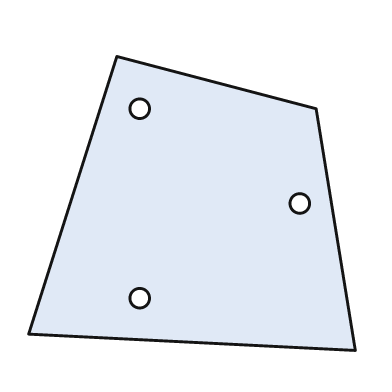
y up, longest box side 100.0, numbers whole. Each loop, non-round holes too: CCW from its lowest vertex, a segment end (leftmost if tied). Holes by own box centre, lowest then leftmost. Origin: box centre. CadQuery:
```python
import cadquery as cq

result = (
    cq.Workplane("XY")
    .moveTo(50.0, -45.0)
    .lineTo(38.0, 29.0)
    .lineTo(-23.0, 45.0)
    .lineTo(-50.0, -40.0)
    .close()
    .moveTo(-16.0, -29.0)
    .circle(3.0)
    .moveTo(33.0, 0.0)
    .circle(3.0)
    .moveTo(-16.0, 29.0)
    .circle(3.0)
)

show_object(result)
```